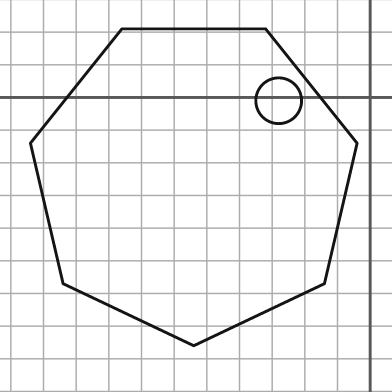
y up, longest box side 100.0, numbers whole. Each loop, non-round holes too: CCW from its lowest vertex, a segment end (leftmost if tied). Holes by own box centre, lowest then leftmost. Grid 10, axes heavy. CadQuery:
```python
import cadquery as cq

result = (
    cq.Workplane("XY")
    .moveTo(-54.0, -76.0)
    .lineTo(-14.0, -57.0)
    .lineTo(-4.0, -14.0)
    .lineTo(-32.0, 21.0)
    .lineTo(-76.0, 21.0)
    .lineTo(-104.0, -14.0)
    .lineTo(-94.0, -57.0)
    .close()
    .moveTo(-28.0, -1.0)
    .circle(7.0)
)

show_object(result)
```